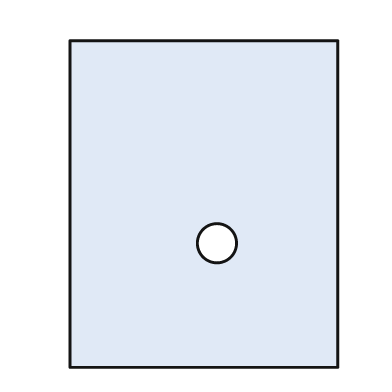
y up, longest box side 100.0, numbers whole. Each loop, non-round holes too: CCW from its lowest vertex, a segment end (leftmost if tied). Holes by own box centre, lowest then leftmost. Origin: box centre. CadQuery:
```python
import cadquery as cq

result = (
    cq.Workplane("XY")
    .moveTo(-41.0, -50.0)
    .lineTo(41.0, -50.0)
    .lineTo(41.0, 50.0)
    .lineTo(-41.0, 50.0)
    .close()
    .moveTo(4.0, -12.0)
    .circle(6.0)
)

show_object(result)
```